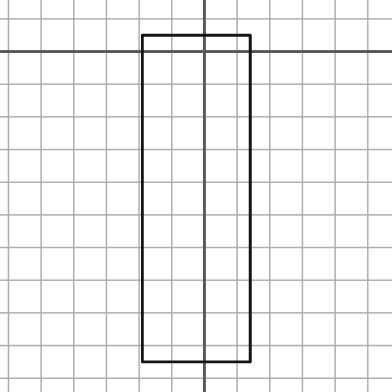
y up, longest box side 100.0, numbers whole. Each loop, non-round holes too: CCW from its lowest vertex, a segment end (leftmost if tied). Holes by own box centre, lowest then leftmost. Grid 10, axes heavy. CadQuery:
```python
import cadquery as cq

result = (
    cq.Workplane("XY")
    .moveTo(-19.0, -95.0)
    .lineTo(14.0, -95.0)
    .lineTo(14.0, 5.0)
    .lineTo(-19.0, 5.0)
    .close()
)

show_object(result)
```